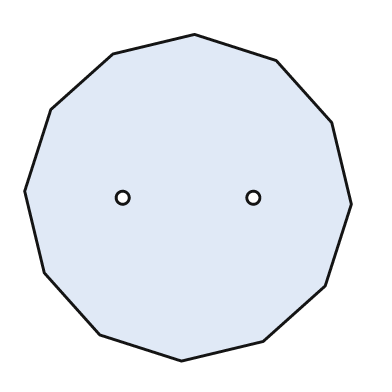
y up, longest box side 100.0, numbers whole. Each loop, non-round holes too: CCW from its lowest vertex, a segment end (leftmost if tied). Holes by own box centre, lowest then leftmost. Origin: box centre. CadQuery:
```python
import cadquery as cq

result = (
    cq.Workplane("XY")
    .moveTo(-2.0, -50.0)
    .lineTo(23.0, -44.0)
    .lineTo(42.0, -27.0)
    .lineTo(50.0, -2.0)
    .lineTo(44.0, 23.0)
    .lineTo(27.0, 42.0)
    .lineTo(2.0, 50.0)
    .lineTo(-23.0, 44.0)
    .lineTo(-42.0, 27.0)
    .lineTo(-50.0, 2.0)
    .lineTo(-44.0, -23.0)
    .lineTo(-27.0, -42.0)
    .close()
    .moveTo(-20.0, 0.0)
    .circle(2.0)
    .moveTo(20.0, 0.0)
    .circle(2.0)
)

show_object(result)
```